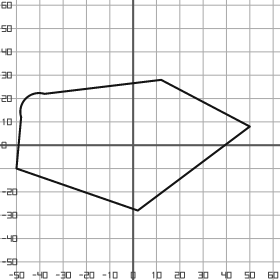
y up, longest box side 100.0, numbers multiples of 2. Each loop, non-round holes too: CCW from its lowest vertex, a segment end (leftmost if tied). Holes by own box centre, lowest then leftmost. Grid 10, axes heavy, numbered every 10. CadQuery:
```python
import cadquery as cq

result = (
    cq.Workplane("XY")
    .moveTo(2.0, -28.0)
    .lineTo(50.0, 8.0)
    .lineTo(12.0, 28.0)
    .lineTo(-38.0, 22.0)
    .threePointArc((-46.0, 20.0), (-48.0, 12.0))
    .lineTo(-50.0, -10.0)
    .close()
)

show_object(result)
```